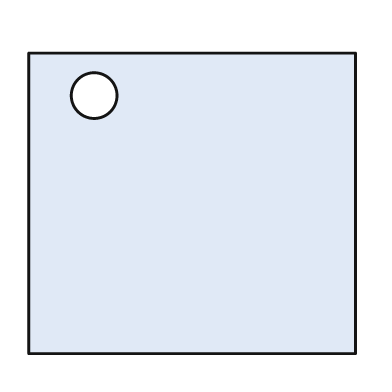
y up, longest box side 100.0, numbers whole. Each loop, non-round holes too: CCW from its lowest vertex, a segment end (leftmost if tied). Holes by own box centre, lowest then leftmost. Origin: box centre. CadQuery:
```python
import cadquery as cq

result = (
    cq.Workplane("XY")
    .moveTo(-50.0, -46.0)
    .lineTo(50.0, -46.0)
    .lineTo(50.0, 46.0)
    .lineTo(-50.0, 46.0)
    .close()
    .moveTo(-30.0, 33.0)
    .circle(7.0)
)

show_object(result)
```